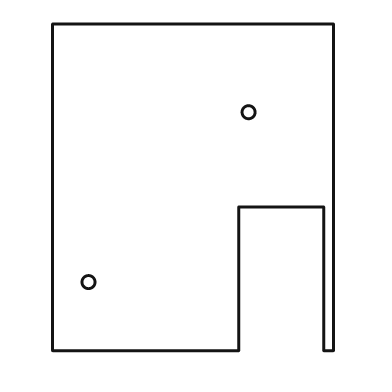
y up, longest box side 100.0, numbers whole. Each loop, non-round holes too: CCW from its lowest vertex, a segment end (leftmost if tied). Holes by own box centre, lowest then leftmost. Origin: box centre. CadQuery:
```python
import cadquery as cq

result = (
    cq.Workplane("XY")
    .moveTo(-43.0, -50.0)
    .lineTo(14.0, -50.0)
    .lineTo(14.0, -6.0)
    .lineTo(40.0, -6.0)
    .lineTo(40.0, -50.0)
    .lineTo(43.0, -50.0)
    .lineTo(43.0, 50.0)
    .lineTo(-43.0, 50.0)
    .close()
    .moveTo(-32.0, -29.0)
    .circle(2.0)
    .moveTo(17.0, 23.0)
    .circle(2.0)
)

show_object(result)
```